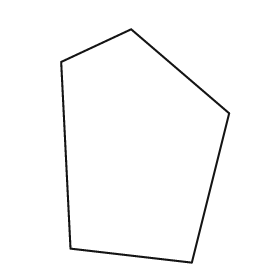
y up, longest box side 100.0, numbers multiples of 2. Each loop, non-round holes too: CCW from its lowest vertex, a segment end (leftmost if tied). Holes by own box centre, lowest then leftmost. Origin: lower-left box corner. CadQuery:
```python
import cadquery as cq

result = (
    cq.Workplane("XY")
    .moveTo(56.0, 0.0)
    .lineTo(72.0, 64.0)
    .lineTo(30.0, 100.0)
    .lineTo(0.0, 86.0)
    .lineTo(4.0, 6.0)
    .close()
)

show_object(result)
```